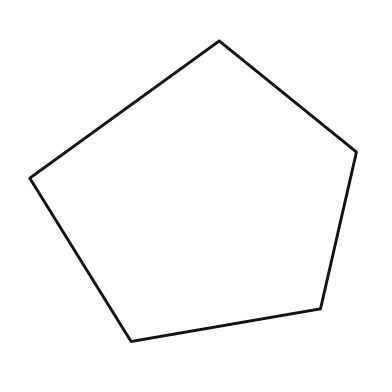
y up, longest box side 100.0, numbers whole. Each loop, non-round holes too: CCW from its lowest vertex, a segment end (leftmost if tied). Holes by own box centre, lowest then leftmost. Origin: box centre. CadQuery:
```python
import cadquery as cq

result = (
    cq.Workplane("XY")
    .moveTo(-19.0, -46.0)
    .lineTo(39.0, -36.0)
    .lineTo(50.0, 12.0)
    .lineTo(8.0, 46.0)
    .lineTo(-50.0, 4.0)
    .close()
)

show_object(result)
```